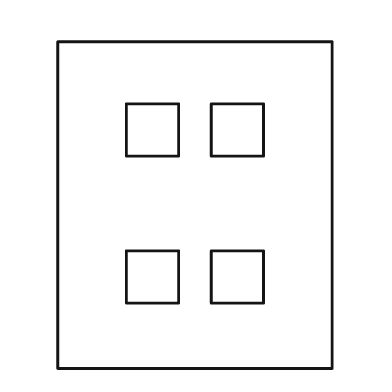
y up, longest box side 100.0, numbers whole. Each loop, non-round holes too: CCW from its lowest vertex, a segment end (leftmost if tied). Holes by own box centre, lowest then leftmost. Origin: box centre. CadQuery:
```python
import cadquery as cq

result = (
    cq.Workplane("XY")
    .moveTo(-42.0, -50.0)
    .lineTo(42.0, -50.0)
    .lineTo(42.0, 50.0)
    .lineTo(-42.0, 50.0)
    .close()
    .moveTo(-21.0, -30.0)
    .lineTo(-5.0, -30.0)
    .lineTo(-5.0, -14.0)
    .lineTo(-21.0, -14.0)
    .close()
    .moveTo(5.0, -30.0)
    .lineTo(21.0, -30.0)
    .lineTo(21.0, -14.0)
    .lineTo(5.0, -14.0)
    .close()
    .moveTo(-21.0, 15.0)
    .lineTo(-5.0, 15.0)
    .lineTo(-5.0, 31.0)
    .lineTo(-21.0, 31.0)
    .close()
    .moveTo(5.0, 15.0)
    .lineTo(21.0, 15.0)
    .lineTo(21.0, 31.0)
    .lineTo(5.0, 31.0)
    .close()
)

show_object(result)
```